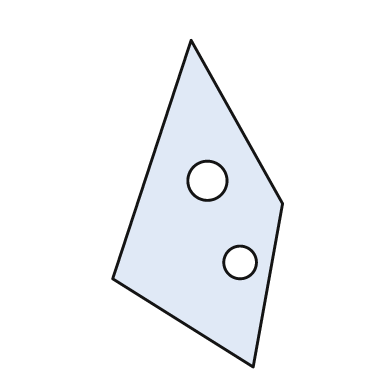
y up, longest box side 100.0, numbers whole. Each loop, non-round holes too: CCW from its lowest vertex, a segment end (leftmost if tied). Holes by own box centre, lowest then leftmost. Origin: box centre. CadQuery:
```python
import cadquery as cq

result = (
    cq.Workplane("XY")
    .moveTo(17.0, -50.0)
    .lineTo(26.0, 0.0)
    .lineTo(-2.0, 50.0)
    .lineTo(-26.0, -23.0)
    .close()
    .moveTo(13.0, -18.0)
    .circle(5.0)
    .moveTo(3.0, 7.0)
    .circle(6.0)
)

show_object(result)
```